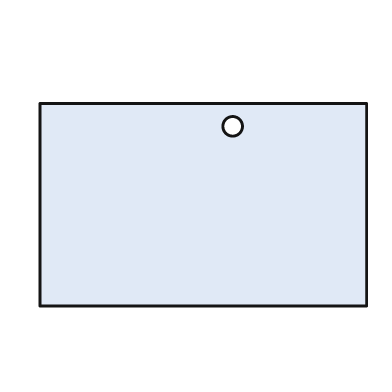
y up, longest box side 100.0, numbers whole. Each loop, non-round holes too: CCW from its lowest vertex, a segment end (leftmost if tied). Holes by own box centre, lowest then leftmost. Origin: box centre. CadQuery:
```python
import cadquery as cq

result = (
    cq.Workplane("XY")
    .moveTo(-50.0, -31.0)
    .lineTo(50.0, -31.0)
    .lineTo(50.0, 31.0)
    .lineTo(-50.0, 31.0)
    .close()
    .moveTo(9.0, 24.0)
    .circle(3.0)
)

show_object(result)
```